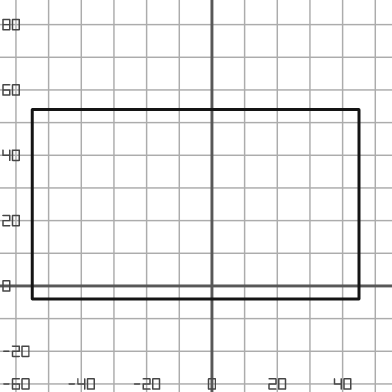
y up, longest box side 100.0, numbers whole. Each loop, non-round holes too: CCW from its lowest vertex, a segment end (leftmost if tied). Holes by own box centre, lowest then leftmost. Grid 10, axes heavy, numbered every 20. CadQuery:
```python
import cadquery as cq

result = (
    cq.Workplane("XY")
    .moveTo(-55.0, -4.0)
    .lineTo(45.0, -4.0)
    .lineTo(45.0, 54.0)
    .lineTo(-55.0, 54.0)
    .close()
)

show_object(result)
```